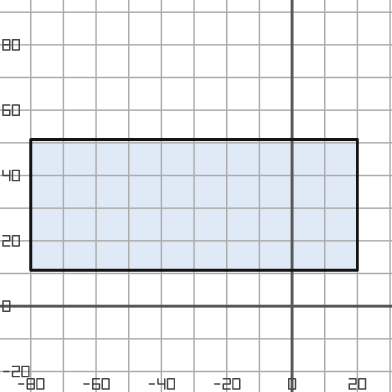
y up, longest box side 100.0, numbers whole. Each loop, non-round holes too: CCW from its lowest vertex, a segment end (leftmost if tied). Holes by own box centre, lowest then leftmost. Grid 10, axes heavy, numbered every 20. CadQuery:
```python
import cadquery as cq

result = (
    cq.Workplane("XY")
    .moveTo(-80.0, 11.0)
    .lineTo(20.0, 11.0)
    .lineTo(20.0, 51.0)
    .lineTo(-80.0, 51.0)
    .close()
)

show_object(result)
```